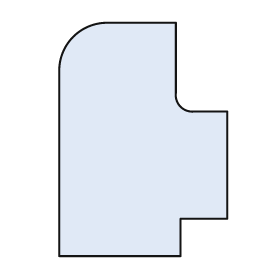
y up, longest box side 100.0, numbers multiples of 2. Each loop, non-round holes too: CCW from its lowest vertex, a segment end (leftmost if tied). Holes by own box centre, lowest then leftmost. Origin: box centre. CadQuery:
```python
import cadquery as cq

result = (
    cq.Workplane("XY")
    .moveTo(-36.0, -50.0)
    .lineTo(16.0, -50.0)
    .lineTo(16.0, -34.0)
    .lineTo(36.0, -34.0)
    .lineTo(36.0, 12.0)
    .lineTo(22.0, 12.0)
    .threePointArc((16.0, 14.0), (14.0, 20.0))
    .lineTo(14.0, 50.0)
    .lineTo(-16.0, 50.0)
    .threePointArc((-30.0, 44.0), (-36.0, 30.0))
    .close()
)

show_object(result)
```